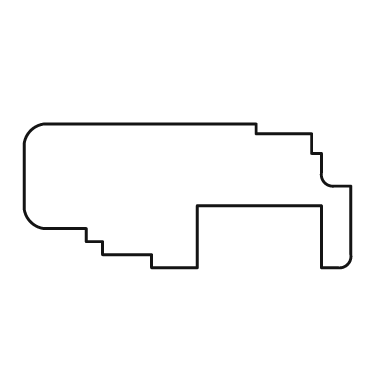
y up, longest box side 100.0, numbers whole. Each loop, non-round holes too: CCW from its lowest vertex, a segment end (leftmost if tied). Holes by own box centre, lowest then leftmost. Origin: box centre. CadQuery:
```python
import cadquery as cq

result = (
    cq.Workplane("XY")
    .moveTo(-11.0, -22.0)
    .lineTo(3.0, -22.0)
    .lineTo(3.0, -3.0)
    .lineTo(41.0, -3.0)
    .lineTo(41.0, -22.0)
    .lineTo(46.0, -22.0)
    .threePointArc((49.0, -21.0), (50.0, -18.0))
    .lineTo(50.0, 3.0)
    .lineTo(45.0, 3.0)
    .threePointArc((42.0, 4.0), (41.0, 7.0))
    .lineTo(41.0, 13.0)
    .lineTo(38.0, 13.0)
    .lineTo(38.0, 19.0)
    .lineTo(21.0, 19.0)
    .lineTo(21.0, 22.0)
    .lineTo(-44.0, 22.0)
    .threePointArc((-48.0, 20.0), (-50.0, 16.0))
    .lineTo(-50.0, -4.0)
    .threePointArc((-48.0, -8.0), (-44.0, -10.0))
    .lineTo(-31.0, -10.0)
    .lineTo(-31.0, -14.0)
    .lineTo(-26.0, -14.0)
    .lineTo(-26.0, -18.0)
    .lineTo(-11.0, -18.0)
    .close()
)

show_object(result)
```